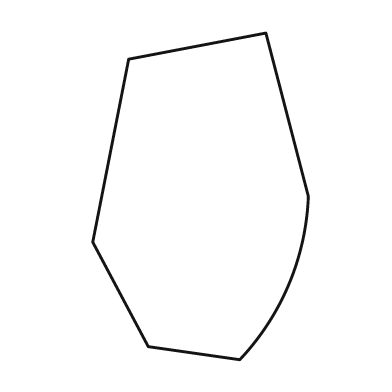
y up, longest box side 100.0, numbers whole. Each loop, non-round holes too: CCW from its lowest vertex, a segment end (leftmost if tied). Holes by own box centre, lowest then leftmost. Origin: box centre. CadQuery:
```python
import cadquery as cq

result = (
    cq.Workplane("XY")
    .moveTo(12.0, -50.0)
    .threePointArc((27.0, -27.0), (33.0, 0.0))
    .lineTo(20.0, 50.0)
    .lineTo(-22.0, 42.0)
    .lineTo(-33.0, -14.0)
    .lineTo(-16.0, -46.0)
    .close()
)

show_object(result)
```